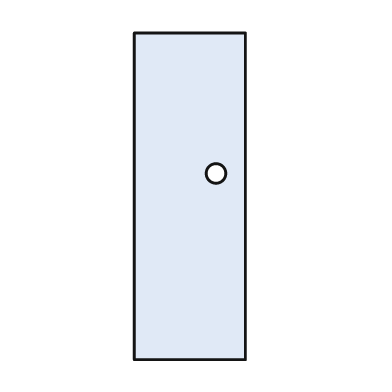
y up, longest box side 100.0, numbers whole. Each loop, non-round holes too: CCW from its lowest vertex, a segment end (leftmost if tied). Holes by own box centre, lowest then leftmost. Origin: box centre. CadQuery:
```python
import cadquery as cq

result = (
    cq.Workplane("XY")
    .moveTo(-17.0, -50.0)
    .lineTo(17.0, -50.0)
    .lineTo(17.0, 50.0)
    .lineTo(-17.0, 50.0)
    .close()
    .moveTo(8.0, 7.0)
    .circle(3.0)
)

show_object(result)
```